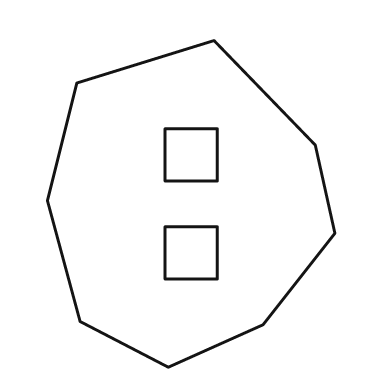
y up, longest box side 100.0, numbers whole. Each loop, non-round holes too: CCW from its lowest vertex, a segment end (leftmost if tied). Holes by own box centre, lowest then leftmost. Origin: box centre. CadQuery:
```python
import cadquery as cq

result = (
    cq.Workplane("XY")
    .moveTo(-7.0, -50.0)
    .lineTo(22.0, -37.0)
    .lineTo(44.0, -9.0)
    .lineTo(38.0, 18.0)
    .lineTo(7.0, 50.0)
    .lineTo(-35.0, 37.0)
    .lineTo(-44.0, 1.0)
    .lineTo(-34.0, -36.0)
    .close()
    .moveTo(-8.0, -23.0)
    .lineTo(8.0, -23.0)
    .lineTo(8.0, -7.0)
    .lineTo(-8.0, -7.0)
    .close()
    .moveTo(-8.0, 7.0)
    .lineTo(8.0, 7.0)
    .lineTo(8.0, 23.0)
    .lineTo(-8.0, 23.0)
    .close()
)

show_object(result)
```